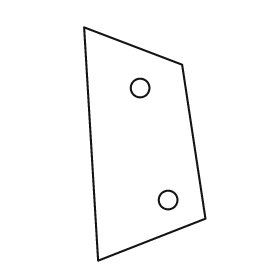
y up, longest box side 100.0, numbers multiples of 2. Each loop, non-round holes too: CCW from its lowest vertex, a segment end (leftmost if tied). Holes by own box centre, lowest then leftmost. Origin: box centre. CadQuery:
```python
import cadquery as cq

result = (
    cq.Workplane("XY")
    .moveTo(-20.0, -50.0)
    .lineTo(26.0, -32.0)
    .lineTo(16.0, 34.0)
    .lineTo(-26.0, 50.0)
    .close()
    .moveTo(10.0, -24.0)
    .circle(4.0)
    .moveTo(-2.0, 24.0)
    .circle(4.0)
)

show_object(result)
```